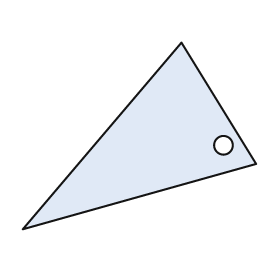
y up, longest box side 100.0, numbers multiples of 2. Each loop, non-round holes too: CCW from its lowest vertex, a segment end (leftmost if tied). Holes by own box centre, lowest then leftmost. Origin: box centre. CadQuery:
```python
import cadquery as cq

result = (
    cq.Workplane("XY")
    .moveTo(-50.0, -40.0)
    .lineTo(50.0, -12.0)
    .lineTo(18.0, 40.0)
    .close()
    .moveTo(36.0, -4.0)
    .circle(4.0)
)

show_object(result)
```